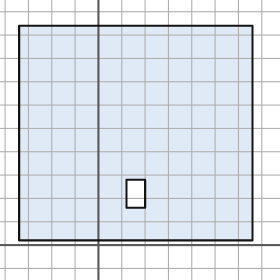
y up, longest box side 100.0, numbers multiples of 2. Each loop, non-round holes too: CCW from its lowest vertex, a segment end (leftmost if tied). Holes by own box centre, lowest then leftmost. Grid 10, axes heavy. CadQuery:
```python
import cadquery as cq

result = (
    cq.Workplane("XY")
    .moveTo(-34.0, 2.0)
    .lineTo(66.0, 2.0)
    .lineTo(66.0, 94.0)
    .lineTo(-34.0, 94.0)
    .close()
    .moveTo(12.0, 16.0)
    .lineTo(20.0, 16.0)
    .lineTo(20.0, 28.0)
    .lineTo(12.0, 28.0)
    .close()
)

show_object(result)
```